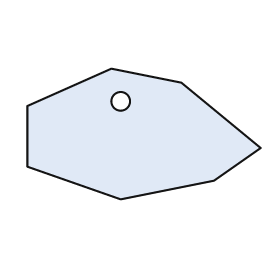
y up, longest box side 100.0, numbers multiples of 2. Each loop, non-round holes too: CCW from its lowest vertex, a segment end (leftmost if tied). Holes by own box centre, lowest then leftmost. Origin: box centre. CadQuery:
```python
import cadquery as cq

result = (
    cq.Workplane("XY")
    .moveTo(-10.0, -28.0)
    .lineTo(30.0, -20.0)
    .lineTo(50.0, -6.0)
    .lineTo(16.0, 22.0)
    .lineTo(-14.0, 28.0)
    .lineTo(-50.0, 12.0)
    .lineTo(-50.0, -14.0)
    .close()
    .moveTo(-10.0, 14.0)
    .circle(4.0)
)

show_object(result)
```